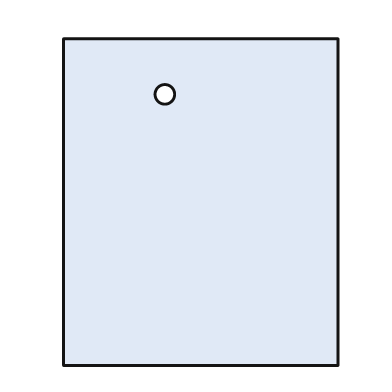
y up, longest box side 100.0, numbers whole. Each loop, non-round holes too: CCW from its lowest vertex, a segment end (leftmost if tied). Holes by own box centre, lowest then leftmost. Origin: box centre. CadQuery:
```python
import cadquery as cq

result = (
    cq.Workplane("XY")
    .moveTo(-42.0, -50.0)
    .lineTo(42.0, -50.0)
    .lineTo(42.0, 50.0)
    .lineTo(-42.0, 50.0)
    .close()
    .moveTo(-11.0, 33.0)
    .circle(3.0)
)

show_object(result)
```